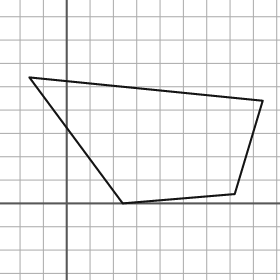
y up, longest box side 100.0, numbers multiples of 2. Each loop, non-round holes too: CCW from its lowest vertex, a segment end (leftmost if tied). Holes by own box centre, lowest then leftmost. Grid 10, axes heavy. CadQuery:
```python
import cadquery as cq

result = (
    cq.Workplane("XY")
    .moveTo(24.0, 0.0)
    .lineTo(72.0, 4.0)
    .lineTo(84.0, 44.0)
    .lineTo(-16.0, 54.0)
    .close()
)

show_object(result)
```